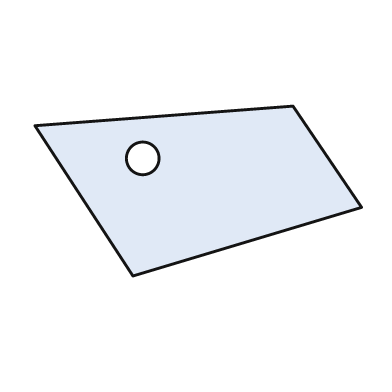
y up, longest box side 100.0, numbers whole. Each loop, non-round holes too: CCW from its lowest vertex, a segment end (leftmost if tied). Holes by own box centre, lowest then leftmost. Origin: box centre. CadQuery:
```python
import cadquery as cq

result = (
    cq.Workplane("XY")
    .moveTo(-20.0, -26.0)
    .lineTo(50.0, -5.0)
    .lineTo(29.0, 26.0)
    .lineTo(-50.0, 20.0)
    .close()
    .moveTo(-17.0, 10.0)
    .circle(5.0)
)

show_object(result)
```